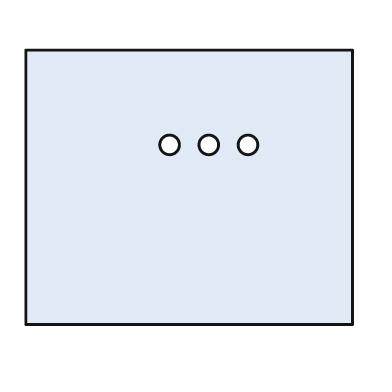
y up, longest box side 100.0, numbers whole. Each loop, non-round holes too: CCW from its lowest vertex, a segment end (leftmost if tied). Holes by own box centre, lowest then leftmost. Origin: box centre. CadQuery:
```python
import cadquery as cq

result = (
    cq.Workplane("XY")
    .moveTo(-50.0, -42.0)
    .lineTo(50.0, -42.0)
    .lineTo(50.0, 42.0)
    .lineTo(-50.0, 42.0)
    .close()
    .moveTo(-6.0, 13.0)
    .circle(3.0)
    .moveTo(6.0, 13.0)
    .circle(3.0)
    .moveTo(18.0, 13.0)
    .circle(3.0)
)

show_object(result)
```